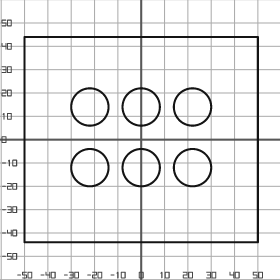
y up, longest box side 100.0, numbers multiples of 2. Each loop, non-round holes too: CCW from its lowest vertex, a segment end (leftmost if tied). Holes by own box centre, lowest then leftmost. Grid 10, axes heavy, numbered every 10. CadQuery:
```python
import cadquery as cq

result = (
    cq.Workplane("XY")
    .moveTo(-50.0, -44.0)
    .lineTo(50.0, -44.0)
    .lineTo(50.0, 44.0)
    .lineTo(-50.0, 44.0)
    .close()
    .moveTo(-22.0, -12.0)
    .circle(8.0)
    .moveTo(0.0, -12.0)
    .circle(8.0)
    .moveTo(22.0, -12.0)
    .circle(8.0)
    .moveTo(-22.0, 14.0)
    .circle(8.0)
    .moveTo(0.0, 14.0)
    .circle(8.0)
    .moveTo(22.0, 14.0)
    .circle(8.0)
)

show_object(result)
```